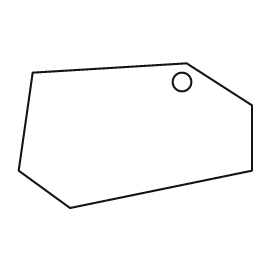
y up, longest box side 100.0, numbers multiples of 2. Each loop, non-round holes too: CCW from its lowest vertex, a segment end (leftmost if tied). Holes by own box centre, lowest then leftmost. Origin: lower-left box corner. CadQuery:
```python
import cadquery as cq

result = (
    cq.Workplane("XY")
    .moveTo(22.0, 0.0)
    .lineTo(100.0, 16.0)
    .lineTo(100.0, 44.0)
    .lineTo(72.0, 62.0)
    .lineTo(6.0, 58.0)
    .lineTo(0.0, 16.0)
    .close()
    .moveTo(70.0, 54.0)
    .circle(4.0)
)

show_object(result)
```